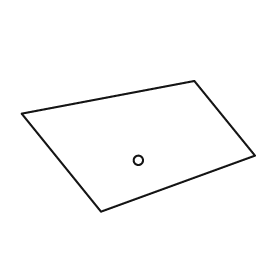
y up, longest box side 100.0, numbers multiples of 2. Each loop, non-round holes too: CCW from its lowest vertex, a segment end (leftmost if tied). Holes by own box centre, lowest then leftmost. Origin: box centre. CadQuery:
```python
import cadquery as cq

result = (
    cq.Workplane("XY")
    .moveTo(-16.0, -28.0)
    .lineTo(50.0, -4.0)
    .lineTo(24.0, 28.0)
    .lineTo(-50.0, 14.0)
    .close()
    .moveTo(0.0, -6.0)
    .circle(2.0)
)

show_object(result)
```